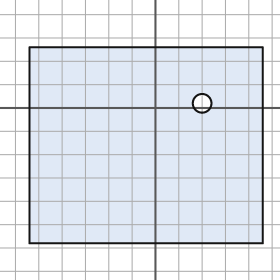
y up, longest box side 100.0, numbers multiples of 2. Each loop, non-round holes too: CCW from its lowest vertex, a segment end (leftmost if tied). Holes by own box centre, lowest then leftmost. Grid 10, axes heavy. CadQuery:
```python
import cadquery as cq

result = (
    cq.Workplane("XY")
    .moveTo(-54.0, -58.0)
    .lineTo(46.0, -58.0)
    .lineTo(46.0, 26.0)
    .lineTo(-54.0, 26.0)
    .close()
    .moveTo(20.0, 2.0)
    .circle(4.0)
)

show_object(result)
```